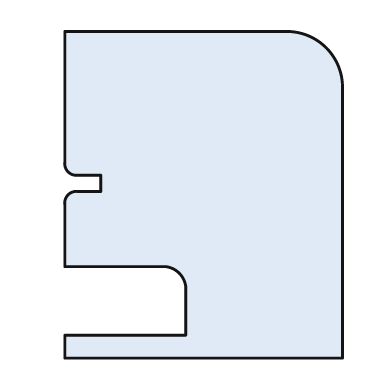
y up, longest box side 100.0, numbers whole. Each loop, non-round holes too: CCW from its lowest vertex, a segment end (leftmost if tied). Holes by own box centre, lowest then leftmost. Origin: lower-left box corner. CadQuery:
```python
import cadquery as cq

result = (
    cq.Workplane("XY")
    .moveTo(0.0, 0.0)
    .lineTo(85.0, 0.0)
    .lineTo(85.0, 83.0)
    .threePointArc((80.0, 95.0), (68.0, 100.0))
    .lineTo(0.0, 100.0)
    .lineTo(0.0, 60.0)
    .threePointArc((1.0, 57.0), (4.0, 56.0))
    .lineTo(11.0, 56.0)
    .lineTo(11.0, 51.0)
    .lineTo(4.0, 51.0)
    .threePointArc((1.0, 50.0), (0.0, 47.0))
    .lineTo(0.0, 28.0)
    .lineTo(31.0, 28.0)
    .threePointArc((35.0, 26.0), (37.0, 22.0))
    .lineTo(37.0, 7.0)
    .lineTo(0.0, 7.0)
    .close()
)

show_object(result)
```